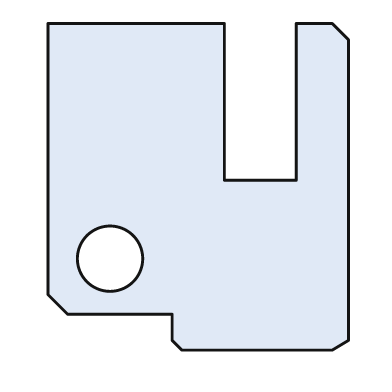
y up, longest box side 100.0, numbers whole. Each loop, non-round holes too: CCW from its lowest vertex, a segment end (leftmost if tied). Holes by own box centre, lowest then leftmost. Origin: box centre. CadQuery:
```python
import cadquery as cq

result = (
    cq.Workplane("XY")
    .moveTo(-5.0, -50.0)
    .lineTo(41.0, -50.0)
    .lineTo(46.0, -47.0)
    .lineTo(46.0, 45.0)
    .lineTo(41.0, 50.0)
    .lineTo(30.0, 50.0)
    .lineTo(30.0, 2.0)
    .lineTo(8.0, 2.0)
    .lineTo(8.0, 50.0)
    .lineTo(-46.0, 50.0)
    .lineTo(-46.0, -33.0)
    .lineTo(-40.0, -39.0)
    .lineTo(-8.0, -39.0)
    .lineTo(-8.0, -47.0)
    .close()
    .moveTo(-27.0, -22.0)
    .circle(10.0)
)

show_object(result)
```